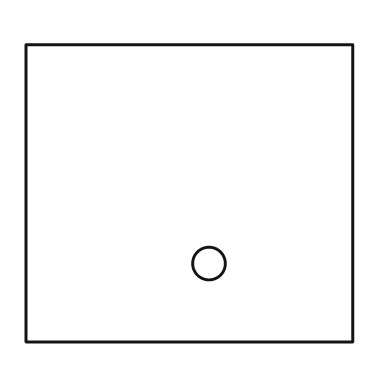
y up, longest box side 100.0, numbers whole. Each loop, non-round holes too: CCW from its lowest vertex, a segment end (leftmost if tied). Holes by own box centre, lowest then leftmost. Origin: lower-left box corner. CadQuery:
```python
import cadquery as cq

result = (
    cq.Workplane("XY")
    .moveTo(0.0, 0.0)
    .lineTo(100.0, 0.0)
    .lineTo(100.0, 91.0)
    .lineTo(0.0, 91.0)
    .close()
    .moveTo(56.0, 24.0)
    .circle(5.0)
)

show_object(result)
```